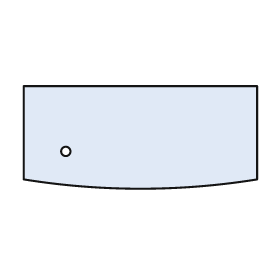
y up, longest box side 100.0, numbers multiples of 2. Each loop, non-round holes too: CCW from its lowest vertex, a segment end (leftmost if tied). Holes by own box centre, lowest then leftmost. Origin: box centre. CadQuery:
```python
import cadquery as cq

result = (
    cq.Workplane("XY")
    .moveTo(-50.0, -18.0)
    .threePointArc((0.0, -22.0), (50.0, -18.0))
    .lineTo(50.0, 22.0)
    .lineTo(-50.0, 22.0)
    .close()
    .moveTo(-32.0, -6.0)
    .circle(2.0)
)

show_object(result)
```